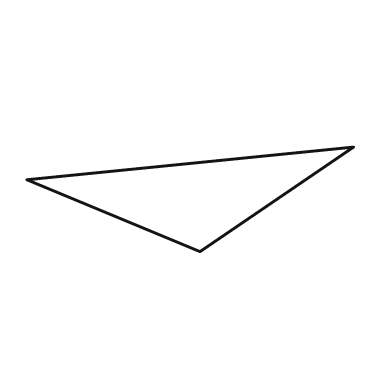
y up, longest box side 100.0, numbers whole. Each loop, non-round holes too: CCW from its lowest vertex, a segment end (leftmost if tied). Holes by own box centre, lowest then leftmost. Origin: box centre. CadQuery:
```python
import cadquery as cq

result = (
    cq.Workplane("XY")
    .moveTo(3.0, -16.0)
    .lineTo(50.0, 16.0)
    .lineTo(-50.0, 6.0)
    .close()
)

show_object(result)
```